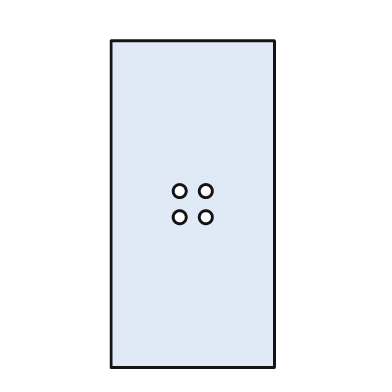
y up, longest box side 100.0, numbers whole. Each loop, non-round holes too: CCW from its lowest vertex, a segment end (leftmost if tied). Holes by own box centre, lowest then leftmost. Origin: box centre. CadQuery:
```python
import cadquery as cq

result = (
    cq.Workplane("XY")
    .moveTo(-25.0, -50.0)
    .lineTo(25.0, -50.0)
    .lineTo(25.0, 50.0)
    .lineTo(-25.0, 50.0)
    .close()
    .moveTo(-4.0, -4.0)
    .circle(2.0)
    .moveTo(4.0, -4.0)
    .circle(2.0)
    .moveTo(-4.0, 4.0)
    .circle(2.0)
    .moveTo(4.0, 4.0)
    .circle(2.0)
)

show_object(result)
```